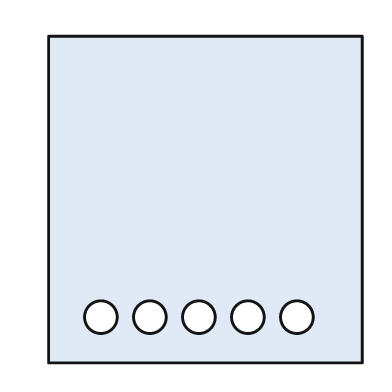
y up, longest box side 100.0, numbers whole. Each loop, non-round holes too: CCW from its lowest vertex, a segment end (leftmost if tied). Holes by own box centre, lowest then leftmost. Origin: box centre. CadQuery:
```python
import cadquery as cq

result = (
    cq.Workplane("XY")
    .moveTo(-48.0, -50.0)
    .lineTo(48.0, -50.0)
    .lineTo(48.0, 50.0)
    .lineTo(-48.0, 50.0)
    .close()
    .moveTo(-32.0, -36.0)
    .circle(5.0)
    .moveTo(-17.0, -36.0)
    .circle(5.0)
    .moveTo(-2.0, -36.0)
    .circle(5.0)
    .moveTo(13.0, -36.0)
    .circle(5.0)
    .moveTo(28.0, -36.0)
    .circle(5.0)
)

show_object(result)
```